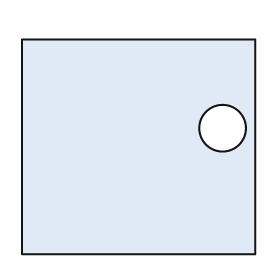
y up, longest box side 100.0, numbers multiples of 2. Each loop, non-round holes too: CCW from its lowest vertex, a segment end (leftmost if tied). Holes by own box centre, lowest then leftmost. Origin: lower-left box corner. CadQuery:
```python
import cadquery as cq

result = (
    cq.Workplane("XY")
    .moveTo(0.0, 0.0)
    .lineTo(100.0, 0.0)
    .lineTo(100.0, 92.0)
    .lineTo(0.0, 92.0)
    .close()
    .moveTo(86.0, 54.0)
    .circle(10.0)
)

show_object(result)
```